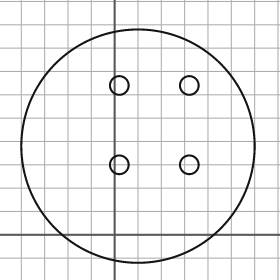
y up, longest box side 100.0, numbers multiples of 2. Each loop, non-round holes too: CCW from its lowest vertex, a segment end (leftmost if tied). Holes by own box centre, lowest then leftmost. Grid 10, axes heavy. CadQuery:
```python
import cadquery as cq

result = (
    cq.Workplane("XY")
    .moveTo(10.0, 38.0)
    .circle(50.0)
    .moveTo(2.0, 30.0)
    .circle(4.0)
    .moveTo(32.0, 30.0)
    .circle(4.0)
    .moveTo(2.0, 64.0)
    .circle(4.0)
    .moveTo(32.0, 64.0)
    .circle(4.0)
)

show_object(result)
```